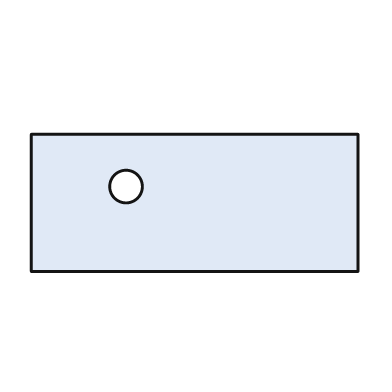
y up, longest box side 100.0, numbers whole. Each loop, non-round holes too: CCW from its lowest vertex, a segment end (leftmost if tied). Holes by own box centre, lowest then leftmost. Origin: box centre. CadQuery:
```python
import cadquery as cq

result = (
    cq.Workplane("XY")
    .moveTo(-50.0, -21.0)
    .lineTo(50.0, -21.0)
    .lineTo(50.0, 21.0)
    .lineTo(-50.0, 21.0)
    .close()
    .moveTo(-21.0, 5.0)
    .circle(5.0)
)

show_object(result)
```